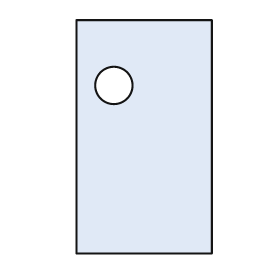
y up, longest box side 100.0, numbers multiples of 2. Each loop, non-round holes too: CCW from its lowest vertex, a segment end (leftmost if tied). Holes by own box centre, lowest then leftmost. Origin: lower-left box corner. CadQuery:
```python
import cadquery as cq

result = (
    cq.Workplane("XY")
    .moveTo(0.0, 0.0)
    .lineTo(58.0, 0.0)
    .lineTo(58.0, 100.0)
    .lineTo(0.0, 100.0)
    .close()
    .moveTo(16.0, 72.0)
    .circle(8.0)
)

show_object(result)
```